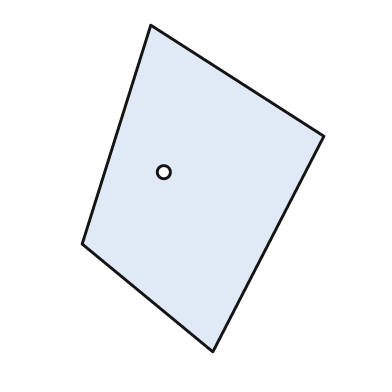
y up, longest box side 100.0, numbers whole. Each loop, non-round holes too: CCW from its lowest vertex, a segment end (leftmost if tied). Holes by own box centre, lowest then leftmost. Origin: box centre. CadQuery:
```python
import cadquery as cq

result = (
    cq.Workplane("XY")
    .moveTo(3.0, -50.0)
    .lineTo(37.0, 16.0)
    .lineTo(-16.0, 50.0)
    .lineTo(-37.0, -17.0)
    .close()
    .moveTo(-12.0, 5.0)
    .circle(2.0)
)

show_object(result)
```